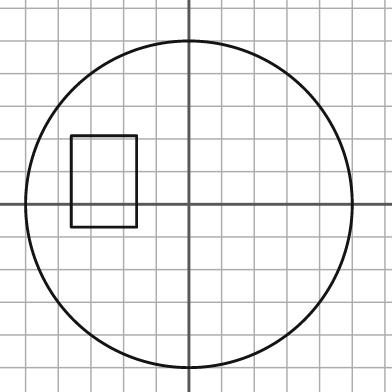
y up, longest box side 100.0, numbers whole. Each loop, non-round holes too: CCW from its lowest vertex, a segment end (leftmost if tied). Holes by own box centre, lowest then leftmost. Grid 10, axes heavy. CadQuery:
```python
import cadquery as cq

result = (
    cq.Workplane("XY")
    .moveTo(0.0, 0.0)
    .circle(50.0)
    .moveTo(-36.0, -7.0)
    .lineTo(-16.0, -7.0)
    .lineTo(-16.0, 21.0)
    .lineTo(-36.0, 21.0)
    .close()
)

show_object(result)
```